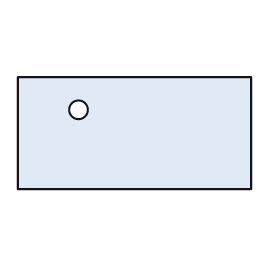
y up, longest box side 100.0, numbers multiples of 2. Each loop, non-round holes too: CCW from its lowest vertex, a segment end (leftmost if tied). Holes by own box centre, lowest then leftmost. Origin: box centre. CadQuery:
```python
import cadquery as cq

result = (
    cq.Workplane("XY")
    .moveTo(-50.0, -24.0)
    .lineTo(50.0, -24.0)
    .lineTo(50.0, 24.0)
    .lineTo(-50.0, 24.0)
    .close()
    .moveTo(-24.0, 10.0)
    .circle(4.0)
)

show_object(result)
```